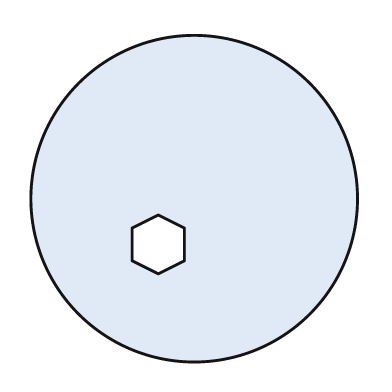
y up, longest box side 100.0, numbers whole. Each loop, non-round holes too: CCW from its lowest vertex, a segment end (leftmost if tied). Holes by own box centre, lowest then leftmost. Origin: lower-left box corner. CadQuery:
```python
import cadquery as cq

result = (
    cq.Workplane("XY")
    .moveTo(50.0, 50.0)
    .circle(50.0)
    .moveTo(39.0, 27.0)
    .lineTo(47.0, 31.0)
    .lineTo(47.0, 41.0)
    .lineTo(39.0, 45.0)
    .lineTo(31.0, 41.0)
    .lineTo(31.0, 31.0)
    .close()
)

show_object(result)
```